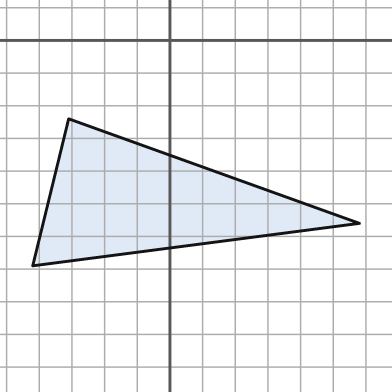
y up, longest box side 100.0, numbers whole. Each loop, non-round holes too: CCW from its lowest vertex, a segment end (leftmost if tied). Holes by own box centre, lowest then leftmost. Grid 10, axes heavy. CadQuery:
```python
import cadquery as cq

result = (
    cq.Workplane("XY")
    .moveTo(-42.0, -69.0)
    .lineTo(58.0, -56.0)
    .lineTo(-31.0, -24.0)
    .close()
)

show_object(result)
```